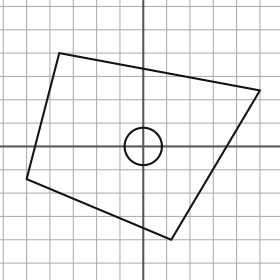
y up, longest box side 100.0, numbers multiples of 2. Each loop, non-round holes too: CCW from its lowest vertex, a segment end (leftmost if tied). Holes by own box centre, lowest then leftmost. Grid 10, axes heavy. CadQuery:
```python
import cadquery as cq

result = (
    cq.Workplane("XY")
    .moveTo(12.0, -40.0)
    .lineTo(50.0, 24.0)
    .lineTo(-36.0, 40.0)
    .lineTo(-50.0, -14.0)
    .close()
    .moveTo(0.0, 0.0)
    .circle(8.0)
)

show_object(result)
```